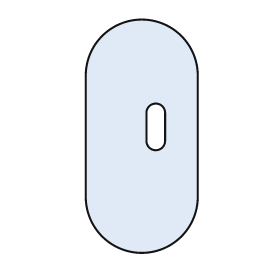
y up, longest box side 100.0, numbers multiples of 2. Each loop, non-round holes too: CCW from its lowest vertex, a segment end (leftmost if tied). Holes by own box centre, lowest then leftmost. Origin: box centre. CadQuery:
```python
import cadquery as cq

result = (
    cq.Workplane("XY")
    .moveTo(-24.0, -26.0)
    .threePointArc((0.0, -50.0), (24.0, -26.0))
    .lineTo(24.0, 26.0)
    .threePointArc((0.0, 50.0), (-24.0, 26.0))
    .close()
    .moveTo(2.0, -2.0)
    .threePointArc((6.0, -6.0), (10.0, -2.0))
    .lineTo(10.0, 10.0)
    .threePointArc((6.0, 14.0), (2.0, 10.0))
    .close()
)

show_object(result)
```